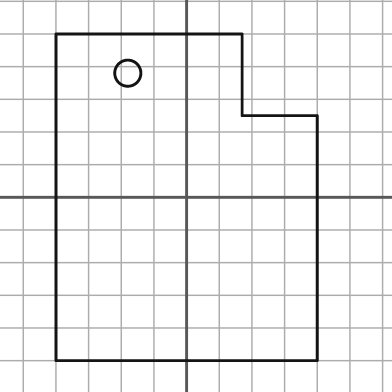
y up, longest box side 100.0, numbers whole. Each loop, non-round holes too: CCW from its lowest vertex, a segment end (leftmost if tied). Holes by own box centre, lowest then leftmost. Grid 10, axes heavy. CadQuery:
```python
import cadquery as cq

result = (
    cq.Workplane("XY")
    .moveTo(-40.0, -50.0)
    .lineTo(40.0, -50.0)
    .lineTo(40.0, 25.0)
    .lineTo(17.0, 25.0)
    .lineTo(17.0, 50.0)
    .lineTo(-40.0, 50.0)
    .close()
    .moveTo(-18.0, 38.0)
    .circle(4.0)
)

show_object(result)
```